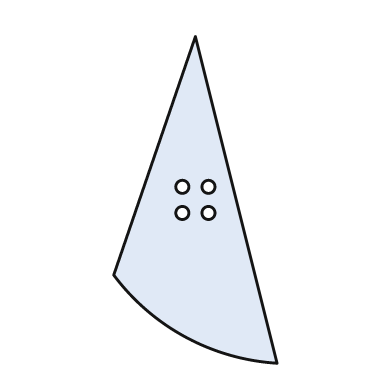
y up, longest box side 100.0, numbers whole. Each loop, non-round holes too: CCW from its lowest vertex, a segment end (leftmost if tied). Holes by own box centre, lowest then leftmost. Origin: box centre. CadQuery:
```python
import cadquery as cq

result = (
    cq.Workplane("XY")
    .moveTo(25.0, -50.0)
    .lineTo(0.0, 50.0)
    .lineTo(-25.0, -23.0)
    .threePointArc((-3.0, -42.0), (25.0, -50.0))
    .close()
    .moveTo(-4.0, -4.0)
    .circle(2.0)
    .moveTo(4.0, -4.0)
    .circle(2.0)
    .moveTo(-4.0, 4.0)
    .circle(2.0)
    .moveTo(4.0, 4.0)
    .circle(2.0)
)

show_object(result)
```